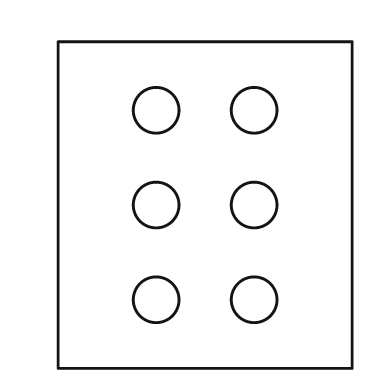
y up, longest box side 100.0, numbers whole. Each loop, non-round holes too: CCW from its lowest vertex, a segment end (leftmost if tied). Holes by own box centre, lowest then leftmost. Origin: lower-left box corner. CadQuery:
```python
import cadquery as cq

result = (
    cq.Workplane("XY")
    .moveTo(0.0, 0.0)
    .lineTo(90.0, 0.0)
    .lineTo(90.0, 100.0)
    .lineTo(0.0, 100.0)
    .close()
    .moveTo(30.0, 21.0)
    .circle(7.0)
    .moveTo(60.0, 21.0)
    .circle(7.0)
    .moveTo(30.0, 50.0)
    .circle(7.0)
    .moveTo(60.0, 50.0)
    .circle(7.0)
    .moveTo(30.0, 79.0)
    .circle(7.0)
    .moveTo(60.0, 79.0)
    .circle(7.0)
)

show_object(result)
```